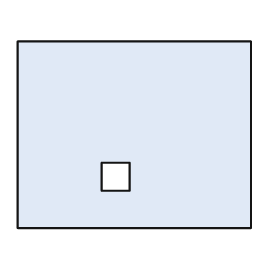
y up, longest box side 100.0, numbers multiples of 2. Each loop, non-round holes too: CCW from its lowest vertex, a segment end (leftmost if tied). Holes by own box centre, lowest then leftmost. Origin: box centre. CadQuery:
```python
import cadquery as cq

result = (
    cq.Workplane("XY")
    .moveTo(-50.0, -40.0)
    .lineTo(50.0, -40.0)
    .lineTo(50.0, 40.0)
    .lineTo(-50.0, 40.0)
    .close()
    .moveTo(-14.0, -24.0)
    .lineTo(-2.0, -24.0)
    .lineTo(-2.0, -12.0)
    .lineTo(-14.0, -12.0)
    .close()
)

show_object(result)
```